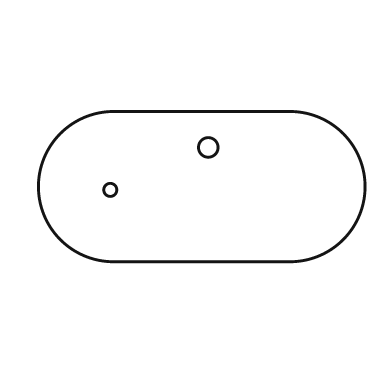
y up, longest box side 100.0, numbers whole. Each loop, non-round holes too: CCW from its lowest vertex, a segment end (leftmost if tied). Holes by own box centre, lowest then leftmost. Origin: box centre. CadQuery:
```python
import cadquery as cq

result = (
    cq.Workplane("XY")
    .moveTo(-27.0, -23.0)
    .lineTo(27.0, -23.0)
    .threePointArc((50.0, 0.0), (27.0, 23.0))
    .lineTo(-27.0, 23.0)
    .threePointArc((-50.0, 0.0), (-27.0, -23.0))
    .close()
    .moveTo(-28.0, -1.0)
    .circle(2.0)
    .moveTo(2.0, 12.0)
    .circle(3.0)
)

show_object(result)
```